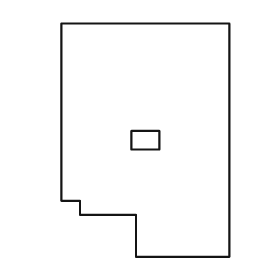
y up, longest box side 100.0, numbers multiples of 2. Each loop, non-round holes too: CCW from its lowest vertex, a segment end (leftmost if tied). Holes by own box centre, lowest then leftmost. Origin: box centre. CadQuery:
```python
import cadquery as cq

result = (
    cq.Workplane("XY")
    .moveTo(-4.0, -50.0)
    .lineTo(36.0, -50.0)
    .lineTo(36.0, 50.0)
    .lineTo(-36.0, 50.0)
    .lineTo(-36.0, -26.0)
    .lineTo(-28.0, -26.0)
    .lineTo(-28.0, -32.0)
    .lineTo(-4.0, -32.0)
    .close()
    .moveTo(-6.0, -4.0)
    .lineTo(6.0, -4.0)
    .lineTo(6.0, 4.0)
    .lineTo(-6.0, 4.0)
    .close()
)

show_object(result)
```